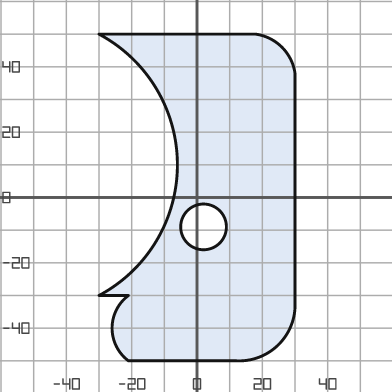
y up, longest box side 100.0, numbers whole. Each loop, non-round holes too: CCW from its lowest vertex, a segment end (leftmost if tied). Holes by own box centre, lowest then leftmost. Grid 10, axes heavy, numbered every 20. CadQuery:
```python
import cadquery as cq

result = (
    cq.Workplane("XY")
    .moveTo(-21.0, -50.0)
    .lineTo(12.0, -50.0)
    .threePointArc((25.0, -45.0), (30.0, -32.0))
    .lineTo(30.0, 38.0)
    .threePointArc((26.0, 46.0), (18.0, 50.0))
    .lineTo(-30.0, 50.0)
    .threePointArc((-6.0, 10.0), (-30.0, -30.0))
    .lineTo(-21.0, -30.0)
    .threePointArc((-26.0, -40.0), (-21.0, -50.0))
    .close()
    .moveTo(2.0, -9.0)
    .circle(7.0)
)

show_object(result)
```